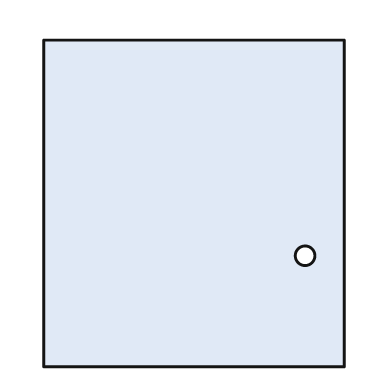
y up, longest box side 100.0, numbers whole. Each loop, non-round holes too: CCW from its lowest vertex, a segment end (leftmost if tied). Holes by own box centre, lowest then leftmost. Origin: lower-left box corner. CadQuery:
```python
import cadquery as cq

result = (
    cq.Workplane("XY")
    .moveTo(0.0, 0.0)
    .lineTo(92.0, 0.0)
    .lineTo(92.0, 100.0)
    .lineTo(0.0, 100.0)
    .close()
    .moveTo(80.0, 34.0)
    .circle(3.0)
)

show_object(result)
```